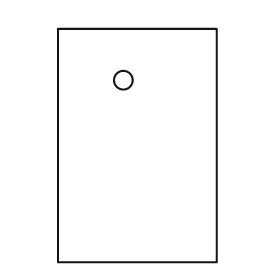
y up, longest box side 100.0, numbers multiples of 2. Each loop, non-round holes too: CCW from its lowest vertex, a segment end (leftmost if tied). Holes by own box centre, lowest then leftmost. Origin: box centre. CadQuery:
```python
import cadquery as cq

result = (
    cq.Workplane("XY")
    .moveTo(-34.0, -50.0)
    .lineTo(34.0, -50.0)
    .lineTo(34.0, 50.0)
    .lineTo(-34.0, 50.0)
    .close()
    .moveTo(-6.0, 28.0)
    .circle(4.0)
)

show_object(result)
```